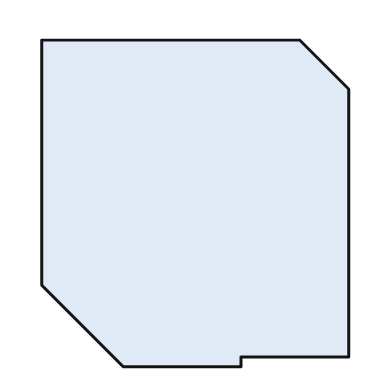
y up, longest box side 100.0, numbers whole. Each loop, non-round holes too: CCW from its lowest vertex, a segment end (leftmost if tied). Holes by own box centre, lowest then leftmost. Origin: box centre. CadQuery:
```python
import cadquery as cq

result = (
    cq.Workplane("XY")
    .moveTo(-22.0, -50.0)
    .lineTo(14.0, -50.0)
    .lineTo(14.0, -47.0)
    .lineTo(47.0, -47.0)
    .lineTo(47.0, 35.0)
    .lineTo(32.0, 50.0)
    .lineTo(-47.0, 50.0)
    .lineTo(-47.0, -25.0)
    .close()
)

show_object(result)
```